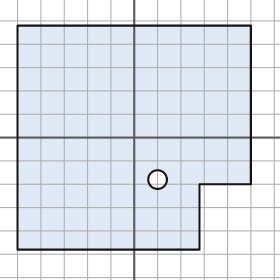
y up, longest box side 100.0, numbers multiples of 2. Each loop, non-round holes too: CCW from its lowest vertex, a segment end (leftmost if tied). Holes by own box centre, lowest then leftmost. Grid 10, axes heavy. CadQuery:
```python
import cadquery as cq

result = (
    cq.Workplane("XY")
    .moveTo(-50.0, -48.0)
    .lineTo(28.0, -48.0)
    .lineTo(28.0, -20.0)
    .lineTo(50.0, -20.0)
    .lineTo(50.0, 48.0)
    .lineTo(-50.0, 48.0)
    .close()
    .moveTo(10.0, -18.0)
    .circle(4.0)
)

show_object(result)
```